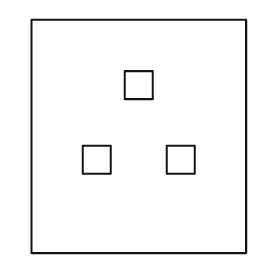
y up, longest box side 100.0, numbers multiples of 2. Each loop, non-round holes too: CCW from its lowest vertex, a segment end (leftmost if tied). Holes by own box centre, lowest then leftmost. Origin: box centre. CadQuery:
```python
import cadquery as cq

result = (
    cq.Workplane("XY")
    .moveTo(-46.0, -50.0)
    .lineTo(46.0, -50.0)
    .lineTo(46.0, 50.0)
    .lineTo(-46.0, 50.0)
    .close()
    .moveTo(-24.0, -16.0)
    .lineTo(-12.0, -16.0)
    .lineTo(-12.0, -4.0)
    .lineTo(-24.0, -4.0)
    .close()
    .moveTo(12.0, -16.0)
    .lineTo(24.0, -16.0)
    .lineTo(24.0, -4.0)
    .lineTo(12.0, -4.0)
    .close()
    .moveTo(-6.0, 16.0)
    .lineTo(6.0, 16.0)
    .lineTo(6.0, 28.0)
    .lineTo(-6.0, 28.0)
    .close()
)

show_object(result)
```